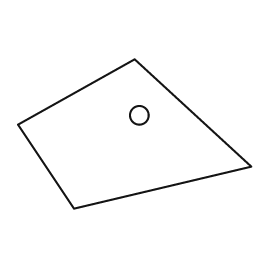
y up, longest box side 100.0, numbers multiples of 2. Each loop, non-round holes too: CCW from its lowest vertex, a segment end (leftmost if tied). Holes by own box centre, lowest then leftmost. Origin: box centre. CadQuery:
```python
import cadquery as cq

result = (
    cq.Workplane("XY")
    .moveTo(-26.0, -32.0)
    .lineTo(50.0, -14.0)
    .lineTo(0.0, 32.0)
    .lineTo(-50.0, 4.0)
    .close()
    .moveTo(2.0, 8.0)
    .circle(4.0)
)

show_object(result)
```